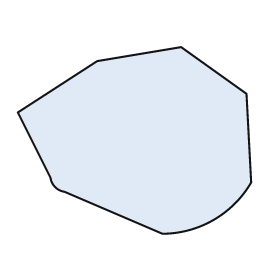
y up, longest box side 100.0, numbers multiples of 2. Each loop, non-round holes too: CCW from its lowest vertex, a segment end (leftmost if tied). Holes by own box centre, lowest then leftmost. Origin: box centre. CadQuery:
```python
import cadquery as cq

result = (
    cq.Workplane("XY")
    .moveTo(12.0, -40.0)
    .threePointArc((34.0, -34.0), (50.0, -18.0))
    .lineTo(48.0, 20.0)
    .lineTo(20.0, 40.0)
    .lineTo(-16.0, 34.0)
    .lineTo(-50.0, 12.0)
    .lineTo(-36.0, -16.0)
    .threePointArc((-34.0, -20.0), (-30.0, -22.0))
    .close()
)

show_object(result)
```